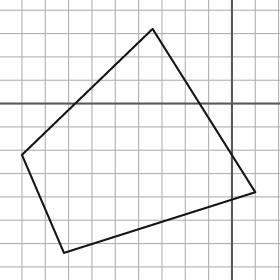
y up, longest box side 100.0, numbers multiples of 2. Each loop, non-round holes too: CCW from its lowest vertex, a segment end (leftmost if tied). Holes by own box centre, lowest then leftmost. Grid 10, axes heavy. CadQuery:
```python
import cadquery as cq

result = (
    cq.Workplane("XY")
    .moveTo(-72.0, -64.0)
    .lineTo(10.0, -38.0)
    .lineTo(-34.0, 32.0)
    .lineTo(-90.0, -22.0)
    .close()
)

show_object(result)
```